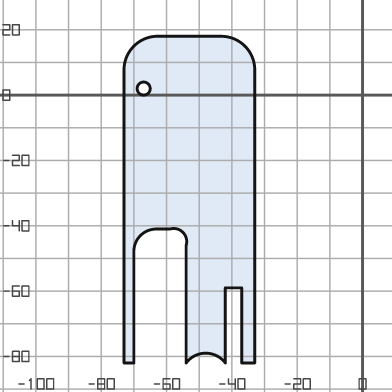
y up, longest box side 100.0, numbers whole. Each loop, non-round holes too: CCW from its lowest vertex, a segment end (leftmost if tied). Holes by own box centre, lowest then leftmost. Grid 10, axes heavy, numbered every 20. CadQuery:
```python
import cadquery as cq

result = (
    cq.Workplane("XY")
    .moveTo(-73.0, -82.0)
    .lineTo(-70.0, -82.0)
    .lineTo(-70.0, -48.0)
    .threePointArc((-68.0, -43.0), (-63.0, -41.0))
    .lineTo(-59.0, -41.0)
    .threePointArc((-55.0, -42.0), (-54.0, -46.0))
    .lineTo(-54.0, -82.0)
    .threePointArc((-48.0, -79.0), (-42.0, -82.0))
    .lineTo(-42.0, -59.0)
    .lineTo(-37.0, -59.0)
    .lineTo(-37.0, -82.0)
    .lineTo(-33.0, -82.0)
    .lineTo(-33.0, 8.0)
    .threePointArc((-36.0, 15.0), (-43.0, 18.0))
    .lineTo(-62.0, 18.0)
    .threePointArc((-70.0, 15.0), (-73.0, 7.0))
    .close()
    .moveTo(-67.0, 2.0)
    .circle(2.0)
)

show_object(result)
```